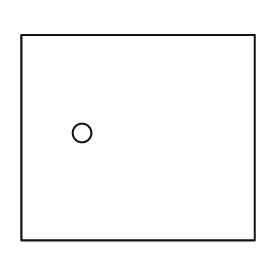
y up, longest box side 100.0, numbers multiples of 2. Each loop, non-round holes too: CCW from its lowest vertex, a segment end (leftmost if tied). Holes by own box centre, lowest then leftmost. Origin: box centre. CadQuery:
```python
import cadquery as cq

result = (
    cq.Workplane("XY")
    .moveTo(-50.0, -44.0)
    .lineTo(50.0, -44.0)
    .lineTo(50.0, 44.0)
    .lineTo(-50.0, 44.0)
    .close()
    .moveTo(-24.0, 2.0)
    .circle(4.0)
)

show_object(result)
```